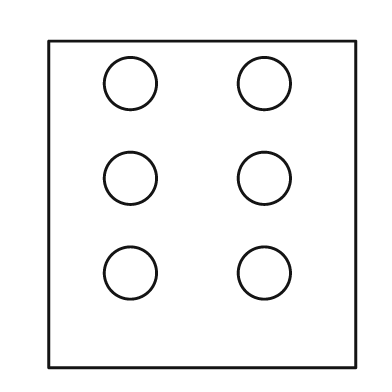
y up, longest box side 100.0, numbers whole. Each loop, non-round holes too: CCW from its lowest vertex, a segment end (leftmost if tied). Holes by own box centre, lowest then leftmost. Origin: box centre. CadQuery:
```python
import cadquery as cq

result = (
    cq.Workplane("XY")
    .moveTo(-47.0, -50.0)
    .lineTo(47.0, -50.0)
    .lineTo(47.0, 50.0)
    .lineTo(-47.0, 50.0)
    .close()
    .moveTo(-22.0, -21.0)
    .circle(8.0)
    .moveTo(19.0, -21.0)
    .circle(8.0)
    .moveTo(-22.0, 8.0)
    .circle(8.0)
    .moveTo(19.0, 8.0)
    .circle(8.0)
    .moveTo(-22.0, 37.0)
    .circle(8.0)
    .moveTo(19.0, 37.0)
    .circle(8.0)
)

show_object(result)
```